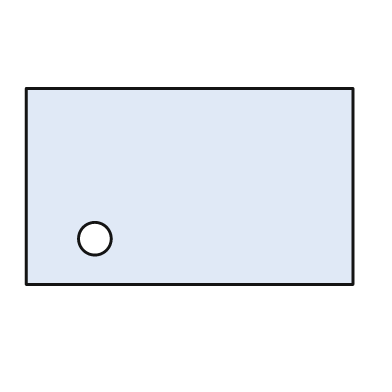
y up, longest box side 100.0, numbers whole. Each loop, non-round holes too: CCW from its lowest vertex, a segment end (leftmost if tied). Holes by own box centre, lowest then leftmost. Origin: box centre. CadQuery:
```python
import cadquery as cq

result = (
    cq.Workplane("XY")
    .moveTo(-50.0, -30.0)
    .lineTo(50.0, -30.0)
    .lineTo(50.0, 30.0)
    .lineTo(-50.0, 30.0)
    .close()
    .moveTo(-29.0, -16.0)
    .circle(5.0)
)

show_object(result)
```